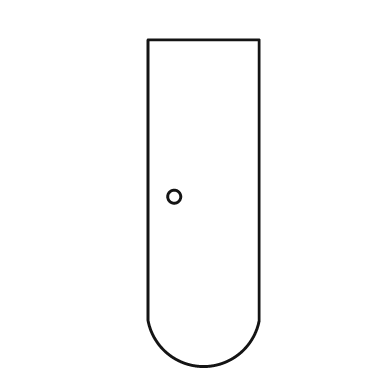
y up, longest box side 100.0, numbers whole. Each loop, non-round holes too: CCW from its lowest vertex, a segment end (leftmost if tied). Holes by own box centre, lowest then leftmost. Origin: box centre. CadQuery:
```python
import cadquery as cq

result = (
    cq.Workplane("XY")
    .moveTo(-17.0, -36.0)
    .threePointArc((0.0, -50.0), (17.0, -36.0))
    .lineTo(17.0, 50.0)
    .lineTo(-17.0, 50.0)
    .close()
    .moveTo(-9.0, 2.0)
    .circle(2.0)
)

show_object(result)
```